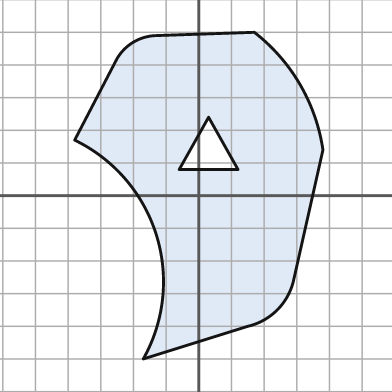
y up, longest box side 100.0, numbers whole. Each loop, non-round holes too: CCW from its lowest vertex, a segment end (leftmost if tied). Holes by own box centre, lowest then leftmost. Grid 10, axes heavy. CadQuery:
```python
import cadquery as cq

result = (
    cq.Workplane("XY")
    .moveTo(-17.0, -50.0)
    .lineTo(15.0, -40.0)
    .threePointArc((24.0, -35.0), (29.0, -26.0))
    .lineTo(38.0, 14.0)
    .threePointArc((31.0, 34.0), (17.0, 50.0))
    .lineTo(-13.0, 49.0)
    .threePointArc((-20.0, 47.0), (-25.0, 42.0))
    .lineTo(-38.0, 17.0)
    .threePointArc((-13.0, -12.0), (-17.0, -50.0))
    .close()
    .moveTo(-6.0, 8.0)
    .lineTo(12.0, 8.0)
    .lineTo(3.0, 24.0)
    .close()
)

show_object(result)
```